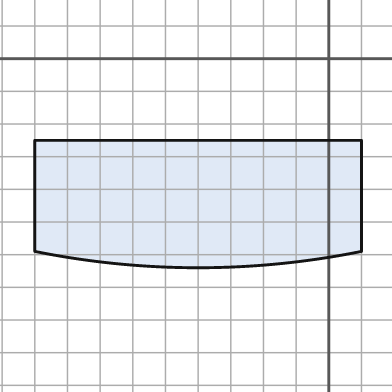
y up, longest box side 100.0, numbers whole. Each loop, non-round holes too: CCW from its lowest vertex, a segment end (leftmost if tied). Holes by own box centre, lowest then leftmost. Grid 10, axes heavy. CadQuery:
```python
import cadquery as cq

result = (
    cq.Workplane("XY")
    .moveTo(-90.0, -59.0)
    .threePointArc((-40.0, -64.0), (10.0, -59.0))
    .lineTo(10.0, -25.0)
    .lineTo(-90.0, -25.0)
    .close()
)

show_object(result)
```